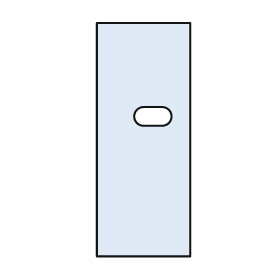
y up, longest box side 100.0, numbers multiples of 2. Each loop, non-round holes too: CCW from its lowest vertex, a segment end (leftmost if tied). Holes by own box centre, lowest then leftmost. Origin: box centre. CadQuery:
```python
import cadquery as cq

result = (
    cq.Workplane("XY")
    .moveTo(-20.0, -50.0)
    .lineTo(20.0, -50.0)
    .lineTo(20.0, 50.0)
    .lineTo(-20.0, 50.0)
    .close()
    .moveTo(0.0, 6.0)
    .lineTo(8.0, 6.0)
    .threePointArc((12.0, 10.0), (8.0, 14.0))
    .lineTo(0.0, 14.0)
    .threePointArc((-4.0, 10.0), (0.0, 6.0))
    .close()
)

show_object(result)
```